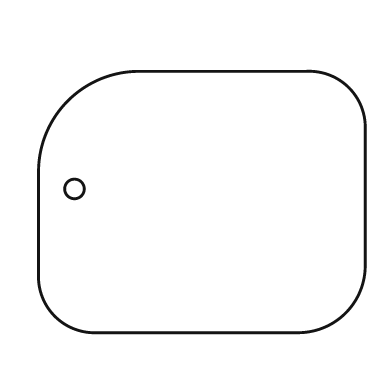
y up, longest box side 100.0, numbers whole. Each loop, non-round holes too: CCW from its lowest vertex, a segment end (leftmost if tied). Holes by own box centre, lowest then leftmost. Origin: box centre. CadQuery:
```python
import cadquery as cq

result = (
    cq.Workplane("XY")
    .moveTo(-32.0, -40.0)
    .lineTo(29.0, -40.0)
    .threePointArc((44.0, -34.0), (50.0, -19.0))
    .lineTo(50.0, 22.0)
    .threePointArc((45.0, 35.0), (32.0, 40.0))
    .lineTo(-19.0, 40.0)
    .threePointArc((-41.0, 31.0), (-50.0, 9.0))
    .lineTo(-50.0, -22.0)
    .threePointArc((-45.0, -35.0), (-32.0, -40.0))
    .close()
    .moveTo(-39.0, 4.0)
    .circle(3.0)
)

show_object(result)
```